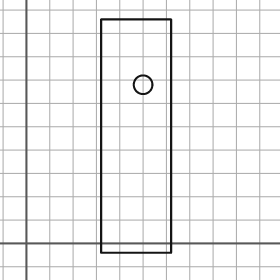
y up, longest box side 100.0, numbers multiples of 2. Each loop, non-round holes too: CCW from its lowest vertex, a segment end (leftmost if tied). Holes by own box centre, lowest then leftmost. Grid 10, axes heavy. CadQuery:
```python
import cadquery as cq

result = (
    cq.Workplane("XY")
    .moveTo(32.0, -4.0)
    .lineTo(62.0, -4.0)
    .lineTo(62.0, 96.0)
    .lineTo(32.0, 96.0)
    .close()
    .moveTo(50.0, 68.0)
    .circle(4.0)
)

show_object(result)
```